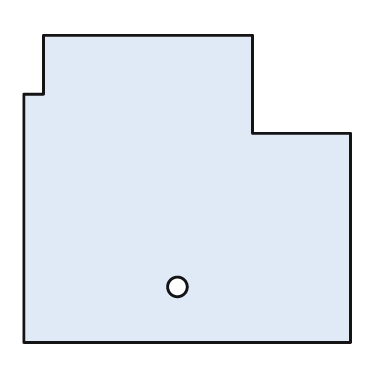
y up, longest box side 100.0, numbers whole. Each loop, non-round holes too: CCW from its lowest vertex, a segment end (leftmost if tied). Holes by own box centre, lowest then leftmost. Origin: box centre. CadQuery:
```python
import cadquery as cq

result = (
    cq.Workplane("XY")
    .moveTo(-50.0, -47.0)
    .lineTo(50.0, -47.0)
    .lineTo(50.0, 17.0)
    .lineTo(20.0, 17.0)
    .lineTo(20.0, 47.0)
    .lineTo(-44.0, 47.0)
    .lineTo(-44.0, 29.0)
    .lineTo(-50.0, 29.0)
    .close()
    .moveTo(-3.0, -30.0)
    .circle(3.0)
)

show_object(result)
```